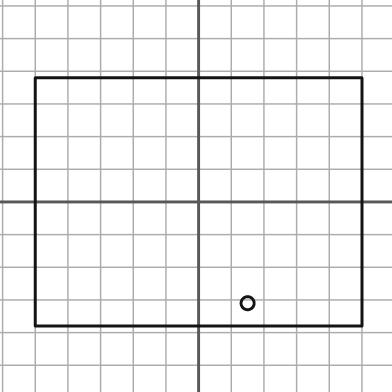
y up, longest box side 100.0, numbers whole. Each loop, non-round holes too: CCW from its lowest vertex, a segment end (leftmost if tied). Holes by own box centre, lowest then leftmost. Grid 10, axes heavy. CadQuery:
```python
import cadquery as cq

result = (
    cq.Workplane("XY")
    .moveTo(-50.0, -38.0)
    .lineTo(50.0, -38.0)
    .lineTo(50.0, 38.0)
    .lineTo(-50.0, 38.0)
    .close()
    .moveTo(15.0, -31.0)
    .circle(2.0)
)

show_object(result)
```